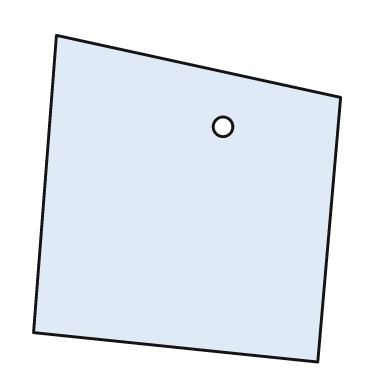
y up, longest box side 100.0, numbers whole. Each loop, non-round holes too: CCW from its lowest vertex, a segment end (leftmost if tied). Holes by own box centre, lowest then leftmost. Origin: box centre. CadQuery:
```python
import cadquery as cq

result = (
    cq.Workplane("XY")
    .moveTo(40.0, -50.0)
    .lineTo(47.0, 31.0)
    .lineTo(-40.0, 50.0)
    .lineTo(-47.0, -41.0)
    .close()
    .moveTo(11.0, 22.0)
    .circle(3.0)
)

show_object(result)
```